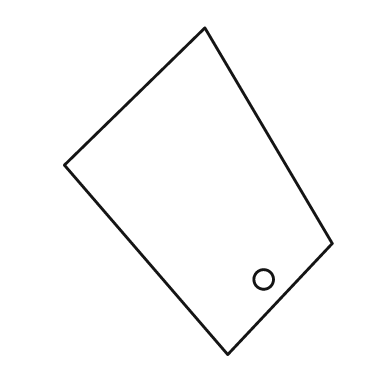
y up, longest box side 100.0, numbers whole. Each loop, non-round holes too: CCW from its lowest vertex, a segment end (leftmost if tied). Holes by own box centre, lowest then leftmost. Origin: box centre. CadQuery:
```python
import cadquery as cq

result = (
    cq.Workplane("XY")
    .moveTo(9.0, -50.0)
    .lineTo(41.0, -16.0)
    .lineTo(2.0, 50.0)
    .lineTo(-41.0, 8.0)
    .close()
    .moveTo(20.0, -27.0)
    .circle(3.0)
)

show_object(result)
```